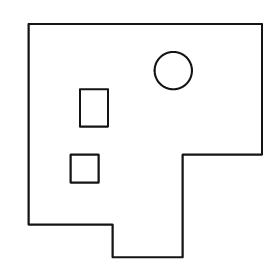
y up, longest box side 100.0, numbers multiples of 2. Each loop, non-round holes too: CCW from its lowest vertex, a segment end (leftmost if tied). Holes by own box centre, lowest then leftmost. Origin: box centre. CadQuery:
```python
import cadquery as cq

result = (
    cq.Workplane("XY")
    .moveTo(-14.0, -50.0)
    .lineTo(16.0, -50.0)
    .lineTo(16.0, -6.0)
    .lineTo(50.0, -6.0)
    .lineTo(50.0, 50.0)
    .lineTo(-50.0, 50.0)
    .lineTo(-50.0, -36.0)
    .lineTo(-14.0, -36.0)
    .close()
    .moveTo(-32.0, -18.0)
    .lineTo(-20.0, -18.0)
    .lineTo(-20.0, -6.0)
    .lineTo(-32.0, -6.0)
    .close()
    .moveTo(-28.0, 6.0)
    .lineTo(-16.0, 6.0)
    .lineTo(-16.0, 22.0)
    .lineTo(-28.0, 22.0)
    .close()
    .moveTo(12.0, 30.0)
    .circle(8.0)
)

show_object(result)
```